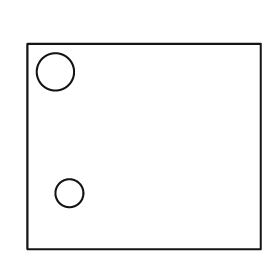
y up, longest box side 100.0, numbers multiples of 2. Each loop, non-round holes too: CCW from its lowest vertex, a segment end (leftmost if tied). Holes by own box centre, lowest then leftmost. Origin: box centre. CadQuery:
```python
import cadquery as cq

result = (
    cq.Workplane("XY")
    .moveTo(-50.0, -44.0)
    .lineTo(50.0, -44.0)
    .lineTo(50.0, 44.0)
    .lineTo(-50.0, 44.0)
    .close()
    .moveTo(-32.0, -20.0)
    .circle(6.0)
    .moveTo(-38.0, 32.0)
    .circle(8.0)
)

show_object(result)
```